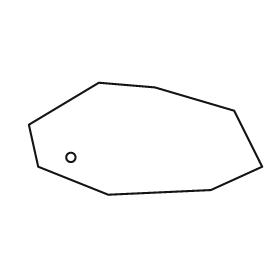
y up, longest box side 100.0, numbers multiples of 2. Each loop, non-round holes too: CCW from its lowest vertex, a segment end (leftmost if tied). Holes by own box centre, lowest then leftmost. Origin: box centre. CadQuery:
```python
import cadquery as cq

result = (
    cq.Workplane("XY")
    .moveTo(-16.0, -24.0)
    .lineTo(28.0, -22.0)
    .lineTo(50.0, -12.0)
    .lineTo(38.0, 12.0)
    .lineTo(4.0, 22.0)
    .lineTo(-20.0, 24.0)
    .lineTo(-50.0, 6.0)
    .lineTo(-46.0, -12.0)
    .close()
    .moveTo(-32.0, -8.0)
    .circle(2.0)
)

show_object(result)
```